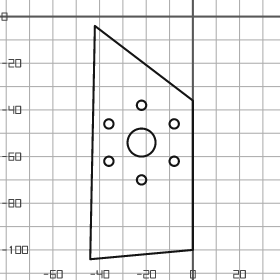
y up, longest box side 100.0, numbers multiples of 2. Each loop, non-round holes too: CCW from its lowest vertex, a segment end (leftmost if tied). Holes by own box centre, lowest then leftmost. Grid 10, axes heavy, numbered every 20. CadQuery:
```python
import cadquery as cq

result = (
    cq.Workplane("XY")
    .moveTo(-44.0, -104.0)
    .lineTo(0.0, -100.0)
    .lineTo(0.0, -36.0)
    .lineTo(-42.0, -4.0)
    .close()
    .moveTo(-22.0, -70.0)
    .circle(2.0)
    .moveTo(-36.0, -62.0)
    .circle(2.0)
    .moveTo(-8.0, -62.0)
    .circle(2.0)
    .moveTo(-22.0, -54.0)
    .circle(6.0)
    .moveTo(-36.0, -46.0)
    .circle(2.0)
    .moveTo(-8.0, -46.0)
    .circle(2.0)
    .moveTo(-22.0, -38.0)
    .circle(2.0)
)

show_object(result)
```